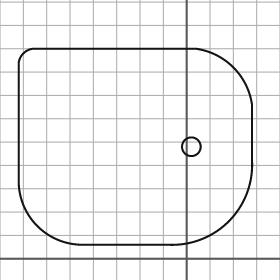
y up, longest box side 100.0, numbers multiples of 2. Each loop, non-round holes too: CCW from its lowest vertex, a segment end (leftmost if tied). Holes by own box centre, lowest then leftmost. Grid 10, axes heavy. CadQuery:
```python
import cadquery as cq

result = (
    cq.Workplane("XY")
    .moveTo(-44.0, 6.0)
    .lineTo(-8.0, 6.0)
    .threePointArc((18.0, 16.0), (28.0, 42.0))
    .lineTo(28.0, 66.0)
    .threePointArc((20.0, 82.0), (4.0, 90.0))
    .lineTo(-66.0, 90.0)
    .threePointArc((-70.0, 88.0), (-72.0, 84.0))
    .lineTo(-72.0, 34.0)
    .threePointArc((-64.0, 14.0), (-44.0, 6.0))
    .close()
    .moveTo(2.0, 48.0)
    .circle(4.0)
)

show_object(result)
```